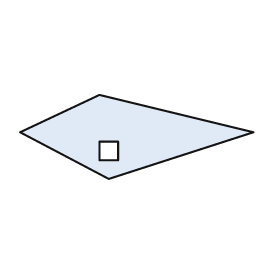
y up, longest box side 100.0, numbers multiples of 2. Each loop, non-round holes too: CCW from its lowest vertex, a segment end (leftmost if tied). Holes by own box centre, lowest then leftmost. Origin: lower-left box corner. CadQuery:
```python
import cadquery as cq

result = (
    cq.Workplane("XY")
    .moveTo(38.0, 0.0)
    .lineTo(100.0, 20.0)
    .lineTo(34.0, 36.0)
    .lineTo(0.0, 20.0)
    .close()
    .moveTo(34.0, 8.0)
    .lineTo(42.0, 8.0)
    .lineTo(42.0, 16.0)
    .lineTo(34.0, 16.0)
    .close()
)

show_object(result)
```